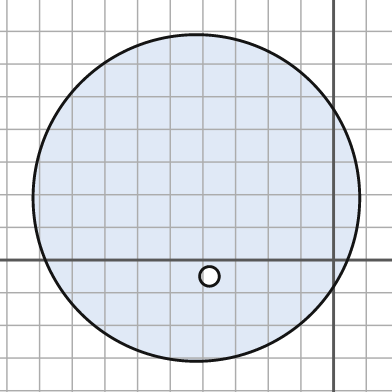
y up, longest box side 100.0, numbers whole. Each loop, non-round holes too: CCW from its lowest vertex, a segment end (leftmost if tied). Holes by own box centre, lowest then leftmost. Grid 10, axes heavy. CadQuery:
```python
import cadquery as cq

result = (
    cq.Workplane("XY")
    .moveTo(-42.0, 19.0)
    .circle(50.0)
    .moveTo(-38.0, -5.0)
    .circle(3.0)
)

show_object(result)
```